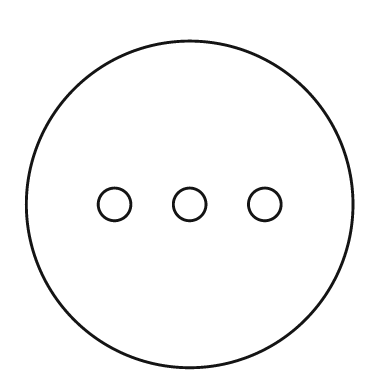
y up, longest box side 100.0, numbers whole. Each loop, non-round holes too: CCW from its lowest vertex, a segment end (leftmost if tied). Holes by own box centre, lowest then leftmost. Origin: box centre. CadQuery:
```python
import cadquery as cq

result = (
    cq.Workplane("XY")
    .moveTo(0.0, 0.0)
    .circle(50.0)
    .moveTo(-23.0, 0.0)
    .circle(5.0)
    .moveTo(0.0, 0.0)
    .circle(5.0)
    .moveTo(23.0, 0.0)
    .circle(5.0)
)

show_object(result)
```